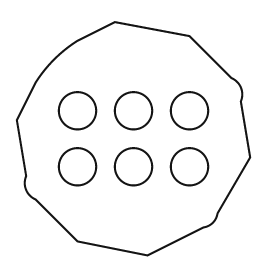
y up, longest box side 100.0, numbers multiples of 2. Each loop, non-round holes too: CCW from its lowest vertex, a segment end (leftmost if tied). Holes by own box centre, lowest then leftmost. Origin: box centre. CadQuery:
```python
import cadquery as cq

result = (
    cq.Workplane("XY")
    .moveTo(6.0, -50.0)
    .lineTo(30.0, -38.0)
    .threePointArc((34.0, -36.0), (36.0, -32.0))
    .lineTo(50.0, -8.0)
    .lineTo(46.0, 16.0)
    .threePointArc((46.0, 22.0), (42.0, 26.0))
    .lineTo(24.0, 44.0)
    .lineTo(-8.0, 50.0)
    .lineTo(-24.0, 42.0)
    .threePointArc((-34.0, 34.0), (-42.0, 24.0))
    .lineTo(-50.0, 8.0)
    .lineTo(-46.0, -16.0)
    .threePointArc((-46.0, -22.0), (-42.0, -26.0))
    .lineTo(-24.0, -44.0)
    .close()
    .moveTo(-24.0, -12.0)
    .circle(8.0)
    .moveTo(0.0, -12.0)
    .circle(8.0)
    .moveTo(24.0, -12.0)
    .circle(8.0)
    .moveTo(-24.0, 12.0)
    .circle(8.0)
    .moveTo(0.0, 12.0)
    .circle(8.0)
    .moveTo(24.0, 12.0)
    .circle(8.0)
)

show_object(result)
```